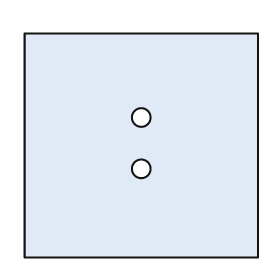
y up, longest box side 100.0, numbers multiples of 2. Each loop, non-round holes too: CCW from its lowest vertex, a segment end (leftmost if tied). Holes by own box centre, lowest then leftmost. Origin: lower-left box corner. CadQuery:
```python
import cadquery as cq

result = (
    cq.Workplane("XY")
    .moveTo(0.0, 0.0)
    .lineTo(100.0, 0.0)
    .lineTo(100.0, 96.0)
    .lineTo(0.0, 96.0)
    .close()
    .moveTo(50.0, 38.0)
    .circle(4.0)
    .moveTo(50.0, 60.0)
    .circle(4.0)
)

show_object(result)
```